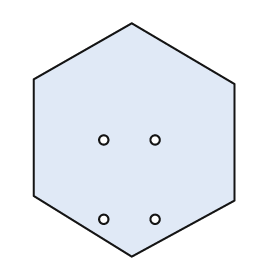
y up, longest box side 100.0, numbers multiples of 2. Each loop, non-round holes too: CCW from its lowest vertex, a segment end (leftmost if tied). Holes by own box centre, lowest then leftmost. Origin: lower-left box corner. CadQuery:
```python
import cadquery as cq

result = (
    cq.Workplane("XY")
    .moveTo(42.0, 0.0)
    .lineTo(86.0, 24.0)
    .lineTo(86.0, 74.0)
    .lineTo(42.0, 100.0)
    .lineTo(0.0, 76.0)
    .lineTo(0.0, 26.0)
    .close()
    .moveTo(30.0, 16.0)
    .circle(2.0)
    .moveTo(52.0, 16.0)
    .circle(2.0)
    .moveTo(30.0, 50.0)
    .circle(2.0)
    .moveTo(52.0, 50.0)
    .circle(2.0)
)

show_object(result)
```